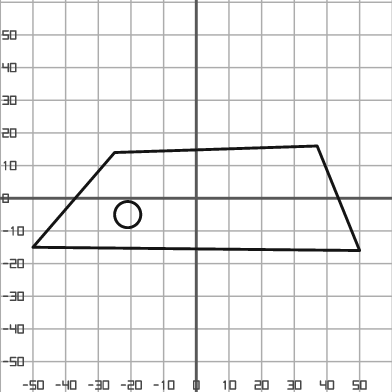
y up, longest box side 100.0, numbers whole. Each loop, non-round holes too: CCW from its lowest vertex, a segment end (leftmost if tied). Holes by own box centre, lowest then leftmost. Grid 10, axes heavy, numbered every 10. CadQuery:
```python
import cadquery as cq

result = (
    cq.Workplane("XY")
    .moveTo(50.0, -16.0)
    .lineTo(37.0, 16.0)
    .lineTo(-25.0, 14.0)
    .lineTo(-50.0, -15.0)
    .close()
    .moveTo(-21.0, -5.0)
    .circle(4.0)
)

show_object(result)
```